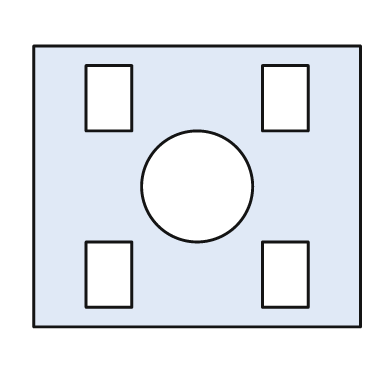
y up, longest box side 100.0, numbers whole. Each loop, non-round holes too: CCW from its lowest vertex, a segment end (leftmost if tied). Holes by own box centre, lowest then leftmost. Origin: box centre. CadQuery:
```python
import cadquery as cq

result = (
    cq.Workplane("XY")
    .moveTo(-50.0, -43.0)
    .lineTo(50.0, -43.0)
    .lineTo(50.0, 43.0)
    .lineTo(-50.0, 43.0)
    .close()
    .moveTo(-34.0, -37.0)
    .lineTo(-20.0, -37.0)
    .lineTo(-20.0, -17.0)
    .lineTo(-34.0, -17.0)
    .close()
    .moveTo(20.0, -37.0)
    .lineTo(34.0, -37.0)
    .lineTo(34.0, -17.0)
    .lineTo(20.0, -17.0)
    .close()
    .moveTo(0.0, 0.0)
    .circle(17.0)
    .moveTo(-34.0, 17.0)
    .lineTo(-20.0, 17.0)
    .lineTo(-20.0, 37.0)
    .lineTo(-34.0, 37.0)
    .close()
    .moveTo(20.0, 17.0)
    .lineTo(34.0, 17.0)
    .lineTo(34.0, 37.0)
    .lineTo(20.0, 37.0)
    .close()
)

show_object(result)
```